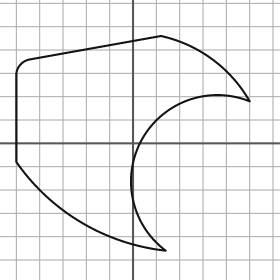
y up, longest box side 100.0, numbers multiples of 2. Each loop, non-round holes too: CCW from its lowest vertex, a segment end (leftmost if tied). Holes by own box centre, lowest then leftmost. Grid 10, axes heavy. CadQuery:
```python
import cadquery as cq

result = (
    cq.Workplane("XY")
    .moveTo(14.0, -46.0)
    .threePointArc((4.0, 2.0), (50.0, 18.0))
    .threePointArc((34.0, 36.0), (12.0, 46.0))
    .lineTo(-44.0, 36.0)
    .threePointArc((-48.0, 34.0), (-50.0, 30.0))
    .lineTo(-50.0, -8.0)
    .threePointArc((-22.0, -34.0), (14.0, -46.0))
    .close()
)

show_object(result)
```